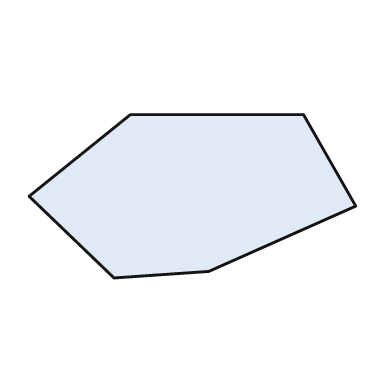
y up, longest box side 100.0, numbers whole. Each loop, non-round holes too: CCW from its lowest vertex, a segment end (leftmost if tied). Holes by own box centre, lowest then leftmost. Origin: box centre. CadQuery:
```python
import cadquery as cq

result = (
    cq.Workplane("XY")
    .moveTo(-24.0, -25.0)
    .lineTo(5.0, -23.0)
    .lineTo(50.0, -3.0)
    .lineTo(34.0, 25.0)
    .lineTo(-19.0, 25.0)
    .lineTo(-50.0, 0.0)
    .close()
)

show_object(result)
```